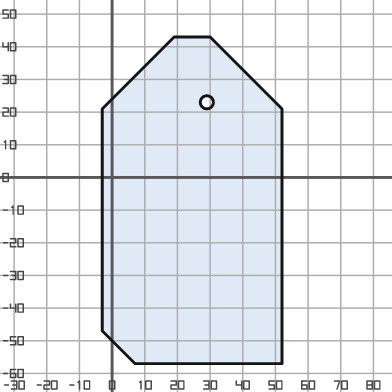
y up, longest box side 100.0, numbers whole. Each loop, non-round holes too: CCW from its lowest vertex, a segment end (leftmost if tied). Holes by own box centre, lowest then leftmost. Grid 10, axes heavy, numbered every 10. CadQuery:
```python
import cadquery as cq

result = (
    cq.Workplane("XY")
    .moveTo(7.0, -57.0)
    .lineTo(52.0, -57.0)
    .lineTo(52.0, 21.0)
    .lineTo(30.0, 43.0)
    .lineTo(19.0, 43.0)
    .lineTo(-3.0, 21.0)
    .lineTo(-3.0, -47.0)
    .close()
    .moveTo(29.0, 23.0)
    .circle(2.0)
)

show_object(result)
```